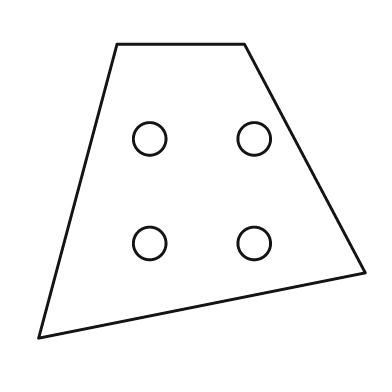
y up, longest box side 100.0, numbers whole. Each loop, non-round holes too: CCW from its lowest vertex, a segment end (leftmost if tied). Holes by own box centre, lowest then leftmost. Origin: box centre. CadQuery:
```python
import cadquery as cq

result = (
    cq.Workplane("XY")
    .moveTo(-50.0, -45.0)
    .lineTo(50.0, -25.0)
    .lineTo(13.0, 45.0)
    .lineTo(-26.0, 45.0)
    .close()
    .moveTo(-16.0, -16.0)
    .circle(5.0)
    .moveTo(16.0, -16.0)
    .circle(5.0)
    .moveTo(-16.0, 16.0)
    .circle(5.0)
    .moveTo(16.0, 16.0)
    .circle(5.0)
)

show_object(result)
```